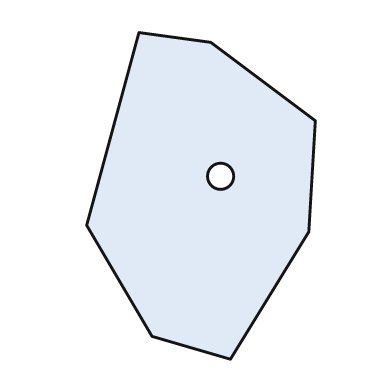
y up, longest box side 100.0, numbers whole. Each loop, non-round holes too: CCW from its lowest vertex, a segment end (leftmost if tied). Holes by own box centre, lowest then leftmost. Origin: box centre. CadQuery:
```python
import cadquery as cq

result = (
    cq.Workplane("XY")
    .moveTo(9.0, -50.0)
    .lineTo(33.0, -11.0)
    .lineTo(35.0, 23.0)
    .lineTo(3.0, 47.0)
    .lineTo(-19.0, 50.0)
    .lineTo(-35.0, -9.0)
    .lineTo(-15.0, -43.0)
    .close()
    .moveTo(6.0, 6.0)
    .circle(4.0)
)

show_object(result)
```